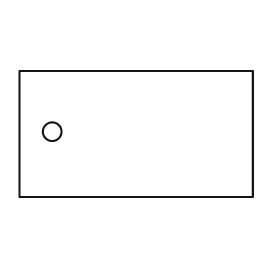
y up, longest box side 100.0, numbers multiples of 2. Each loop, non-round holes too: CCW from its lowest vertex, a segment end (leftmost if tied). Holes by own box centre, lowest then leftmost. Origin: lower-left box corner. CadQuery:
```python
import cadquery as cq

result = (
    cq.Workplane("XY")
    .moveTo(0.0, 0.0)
    .lineTo(100.0, 0.0)
    .lineTo(100.0, 54.0)
    .lineTo(0.0, 54.0)
    .close()
    .moveTo(14.0, 28.0)
    .circle(4.0)
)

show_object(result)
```